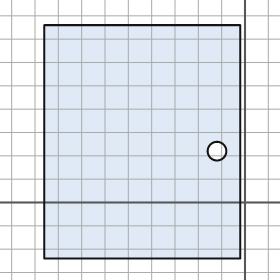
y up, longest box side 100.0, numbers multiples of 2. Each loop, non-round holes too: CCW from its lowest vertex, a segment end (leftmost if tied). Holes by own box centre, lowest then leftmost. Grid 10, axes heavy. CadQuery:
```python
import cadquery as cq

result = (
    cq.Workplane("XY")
    .moveTo(-86.0, -24.0)
    .lineTo(-2.0, -24.0)
    .lineTo(-2.0, 76.0)
    .lineTo(-86.0, 76.0)
    .close()
    .moveTo(-12.0, 22.0)
    .circle(4.0)
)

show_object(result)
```